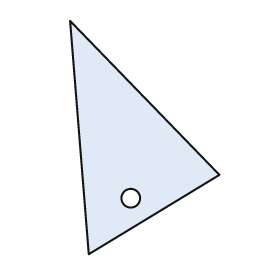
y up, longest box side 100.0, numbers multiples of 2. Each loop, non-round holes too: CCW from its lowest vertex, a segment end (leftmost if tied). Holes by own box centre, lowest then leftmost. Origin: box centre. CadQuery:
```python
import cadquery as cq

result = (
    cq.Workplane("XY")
    .moveTo(-24.0, -50.0)
    .lineTo(32.0, -16.0)
    .lineTo(-32.0, 50.0)
    .close()
    .moveTo(-6.0, -26.0)
    .circle(4.0)
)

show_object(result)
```